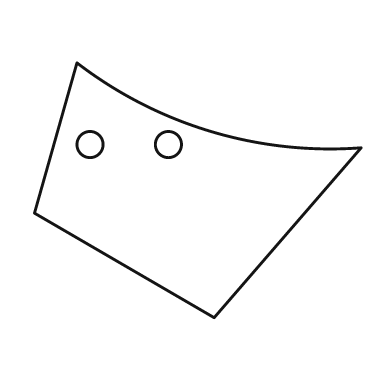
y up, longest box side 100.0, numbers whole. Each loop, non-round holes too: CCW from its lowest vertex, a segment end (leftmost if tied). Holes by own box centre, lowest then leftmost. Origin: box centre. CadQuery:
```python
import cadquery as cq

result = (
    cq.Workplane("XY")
    .moveTo(5.0, -39.0)
    .lineTo(50.0, 13.0)
    .threePointArc((4.0, 18.0), (-37.0, 39.0))
    .lineTo(-50.0, -7.0)
    .close()
    .moveTo(-33.0, 14.0)
    .circle(4.0)
    .moveTo(-9.0, 14.0)
    .circle(4.0)
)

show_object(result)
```